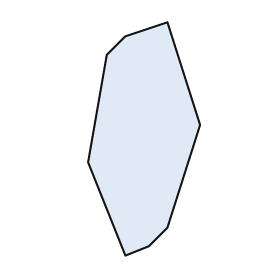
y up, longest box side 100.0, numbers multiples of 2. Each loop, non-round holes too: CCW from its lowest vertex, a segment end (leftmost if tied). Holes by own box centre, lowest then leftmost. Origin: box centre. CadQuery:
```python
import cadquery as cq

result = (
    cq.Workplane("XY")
    .moveTo(-8.0, -50.0)
    .lineTo(2.0, -46.0)
    .lineTo(10.0, -38.0)
    .lineTo(24.0, 6.0)
    .lineTo(10.0, 50.0)
    .lineTo(-8.0, 44.0)
    .lineTo(-16.0, 36.0)
    .lineTo(-24.0, -10.0)
    .close()
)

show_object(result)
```